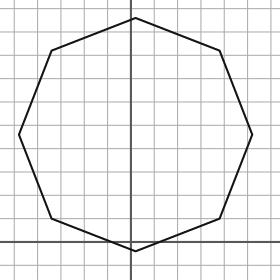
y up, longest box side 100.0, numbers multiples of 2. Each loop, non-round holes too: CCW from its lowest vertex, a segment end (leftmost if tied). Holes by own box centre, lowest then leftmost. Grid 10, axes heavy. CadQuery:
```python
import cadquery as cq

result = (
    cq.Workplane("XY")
    .moveTo(2.0, -4.0)
    .lineTo(38.0, 10.0)
    .lineTo(52.0, 46.0)
    .lineTo(38.0, 82.0)
    .lineTo(2.0, 96.0)
    .lineTo(-34.0, 82.0)
    .lineTo(-48.0, 46.0)
    .lineTo(-34.0, 10.0)
    .close()
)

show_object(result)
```